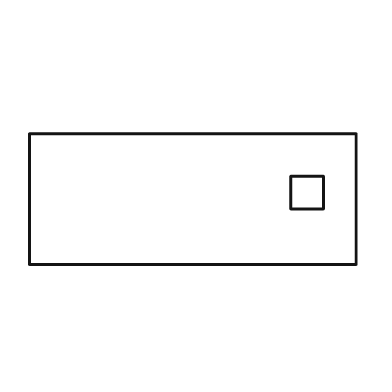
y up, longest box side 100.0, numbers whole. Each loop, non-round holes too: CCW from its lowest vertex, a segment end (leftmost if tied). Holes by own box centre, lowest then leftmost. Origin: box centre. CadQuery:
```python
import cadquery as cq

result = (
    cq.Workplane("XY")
    .moveTo(-50.0, -20.0)
    .lineTo(50.0, -20.0)
    .lineTo(50.0, 20.0)
    .lineTo(-50.0, 20.0)
    .close()
    .moveTo(30.0, -3.0)
    .lineTo(40.0, -3.0)
    .lineTo(40.0, 7.0)
    .lineTo(30.0, 7.0)
    .close()
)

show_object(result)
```